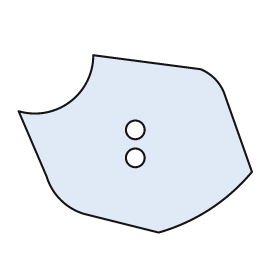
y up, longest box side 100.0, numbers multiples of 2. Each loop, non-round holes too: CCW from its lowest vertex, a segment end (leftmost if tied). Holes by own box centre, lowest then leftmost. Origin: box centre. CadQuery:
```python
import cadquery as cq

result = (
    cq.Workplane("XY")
    .moveTo(10.0, -38.0)
    .threePointArc((32.0, -28.0), (50.0, -12.0))
    .lineTo(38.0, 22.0)
    .threePointArc((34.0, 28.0), (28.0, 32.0))
    .lineTo(-18.0, 38.0)
    .threePointArc((-28.0, 18.0), (-50.0, 14.0))
    .lineTo(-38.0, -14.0)
    .threePointArc((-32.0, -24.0), (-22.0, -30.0))
    .close()
    .moveTo(0.0, -6.0)
    .circle(4.0)
    .moveTo(0.0, 6.0)
    .circle(4.0)
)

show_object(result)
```